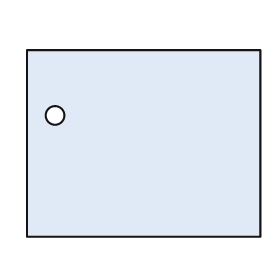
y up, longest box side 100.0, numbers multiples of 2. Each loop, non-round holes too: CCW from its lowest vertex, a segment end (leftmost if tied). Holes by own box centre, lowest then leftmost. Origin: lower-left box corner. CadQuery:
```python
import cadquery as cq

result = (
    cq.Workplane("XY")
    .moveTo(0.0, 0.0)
    .lineTo(100.0, 0.0)
    .lineTo(100.0, 80.0)
    .lineTo(0.0, 80.0)
    .close()
    .moveTo(12.0, 52.0)
    .circle(4.0)
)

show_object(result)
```